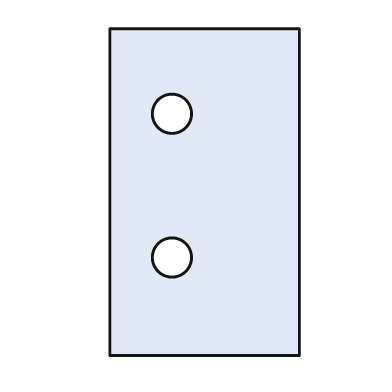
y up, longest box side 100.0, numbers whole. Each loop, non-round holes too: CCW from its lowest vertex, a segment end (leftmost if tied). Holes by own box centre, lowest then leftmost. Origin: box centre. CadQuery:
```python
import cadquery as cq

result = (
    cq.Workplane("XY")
    .moveTo(-29.0, -50.0)
    .lineTo(29.0, -50.0)
    .lineTo(29.0, 50.0)
    .lineTo(-29.0, 50.0)
    .close()
    .moveTo(-10.0, -20.0)
    .circle(6.0)
    .moveTo(-10.0, 24.0)
    .circle(6.0)
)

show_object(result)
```